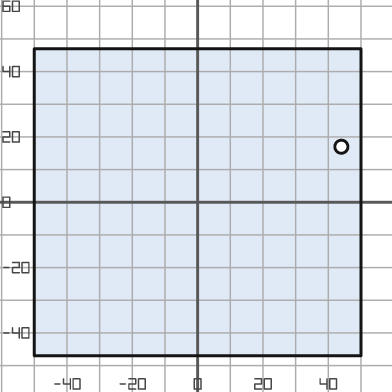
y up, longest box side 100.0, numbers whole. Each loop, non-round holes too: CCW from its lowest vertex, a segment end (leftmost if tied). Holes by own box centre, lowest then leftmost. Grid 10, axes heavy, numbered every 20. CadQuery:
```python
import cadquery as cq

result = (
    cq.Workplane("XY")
    .moveTo(-50.0, -47.0)
    .lineTo(50.0, -47.0)
    .lineTo(50.0, 47.0)
    .lineTo(-50.0, 47.0)
    .close()
    .moveTo(44.0, 17.0)
    .circle(2.0)
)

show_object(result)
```